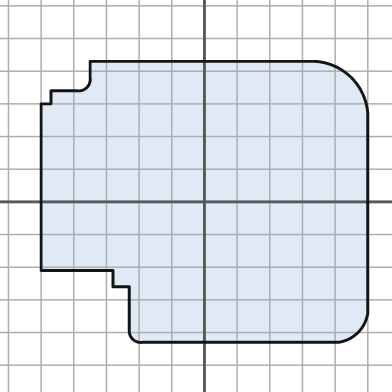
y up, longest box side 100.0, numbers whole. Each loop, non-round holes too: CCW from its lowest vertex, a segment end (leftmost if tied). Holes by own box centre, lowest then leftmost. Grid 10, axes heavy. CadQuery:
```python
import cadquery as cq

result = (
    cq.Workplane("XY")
    .moveTo(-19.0, -43.0)
    .lineTo(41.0, -43.0)
    .threePointArc((47.0, -40.0), (50.0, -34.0))
    .lineTo(50.0, 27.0)
    .threePointArc((45.0, 38.0), (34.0, 43.0))
    .lineTo(-35.0, 43.0)
    .lineTo(-35.0, 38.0)
    .threePointArc((-36.0, 35.0), (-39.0, 34.0))
    .lineTo(-47.0, 34.0)
    .lineTo(-47.0, 30.0)
    .lineTo(-50.0, 30.0)
    .lineTo(-50.0, -21.0)
    .lineTo(-28.0, -21.0)
    .lineTo(-28.0, -26.0)
    .lineTo(-23.0, -26.0)
    .lineTo(-23.0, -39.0)
    .threePointArc((-22.0, -42.0), (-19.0, -43.0))
    .close()
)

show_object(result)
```